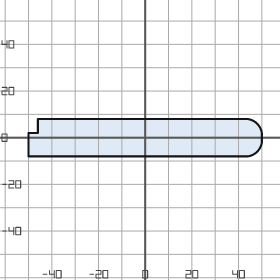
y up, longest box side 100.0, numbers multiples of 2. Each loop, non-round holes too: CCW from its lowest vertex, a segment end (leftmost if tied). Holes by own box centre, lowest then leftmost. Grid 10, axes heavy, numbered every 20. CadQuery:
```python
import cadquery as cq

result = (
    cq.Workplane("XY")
    .moveTo(-50.0, -8.0)
    .lineTo(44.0, -8.0)
    .threePointArc((48.0, -6.0), (50.0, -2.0))
    .lineTo(50.0, 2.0)
    .threePointArc((48.0, 6.0), (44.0, 8.0))
    .lineTo(-46.0, 8.0)
    .lineTo(-46.0, 2.0)
    .lineTo(-50.0, 2.0)
    .close()
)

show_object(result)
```